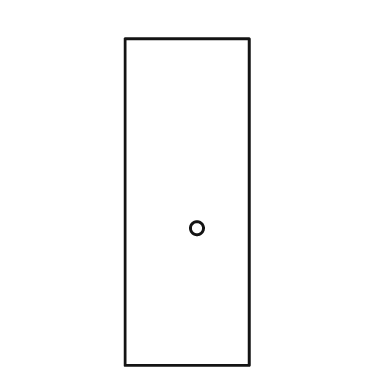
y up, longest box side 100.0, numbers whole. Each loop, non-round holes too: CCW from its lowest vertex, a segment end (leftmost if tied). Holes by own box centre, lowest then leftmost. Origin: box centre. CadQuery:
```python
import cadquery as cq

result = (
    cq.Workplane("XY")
    .moveTo(-19.0, -50.0)
    .lineTo(19.0, -50.0)
    .lineTo(19.0, 50.0)
    .lineTo(-19.0, 50.0)
    .close()
    .moveTo(3.0, -8.0)
    .circle(2.0)
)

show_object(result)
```